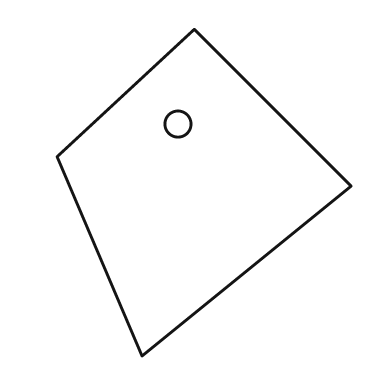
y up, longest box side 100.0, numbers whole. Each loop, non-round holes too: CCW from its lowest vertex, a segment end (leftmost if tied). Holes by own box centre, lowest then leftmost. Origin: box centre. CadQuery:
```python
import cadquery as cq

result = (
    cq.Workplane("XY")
    .moveTo(-19.0, -50.0)
    .lineTo(45.0, 2.0)
    .lineTo(-3.0, 50.0)
    .lineTo(-45.0, 11.0)
    .close()
    .moveTo(-8.0, 21.0)
    .circle(4.0)
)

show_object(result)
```